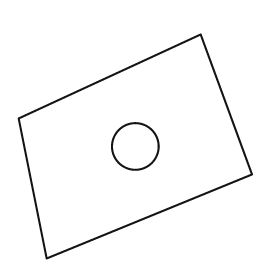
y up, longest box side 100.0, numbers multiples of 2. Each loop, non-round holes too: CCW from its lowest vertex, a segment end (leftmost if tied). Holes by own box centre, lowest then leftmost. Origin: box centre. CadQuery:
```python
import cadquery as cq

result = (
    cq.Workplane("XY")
    .moveTo(-38.0, -48.0)
    .lineTo(50.0, -12.0)
    .lineTo(28.0, 48.0)
    .lineTo(-50.0, 12.0)
    .close()
    .moveTo(0.0, 0.0)
    .circle(10.0)
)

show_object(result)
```